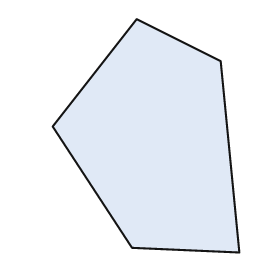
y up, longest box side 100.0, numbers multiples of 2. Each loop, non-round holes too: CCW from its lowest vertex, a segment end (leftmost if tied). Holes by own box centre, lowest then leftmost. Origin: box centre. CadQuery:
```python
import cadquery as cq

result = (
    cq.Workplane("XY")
    .moveTo(40.0, -50.0)
    .lineTo(32.0, 32.0)
    .lineTo(-4.0, 50.0)
    .lineTo(-40.0, 4.0)
    .lineTo(-6.0, -48.0)
    .close()
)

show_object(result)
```